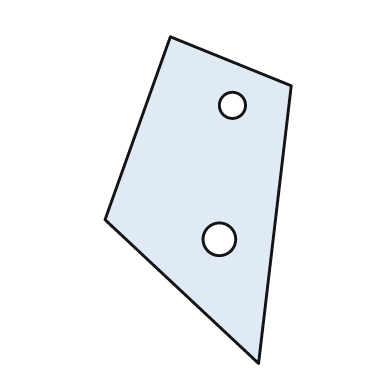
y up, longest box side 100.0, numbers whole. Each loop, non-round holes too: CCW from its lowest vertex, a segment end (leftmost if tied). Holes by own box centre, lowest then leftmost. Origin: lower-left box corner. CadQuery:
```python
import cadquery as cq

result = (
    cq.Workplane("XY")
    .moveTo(47.0, 0.0)
    .lineTo(57.0, 85.0)
    .lineTo(20.0, 100.0)
    .lineTo(0.0, 44.0)
    .close()
    .moveTo(35.0, 38.0)
    .circle(5.0)
    .moveTo(39.0, 79.0)
    .circle(4.0)
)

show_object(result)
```